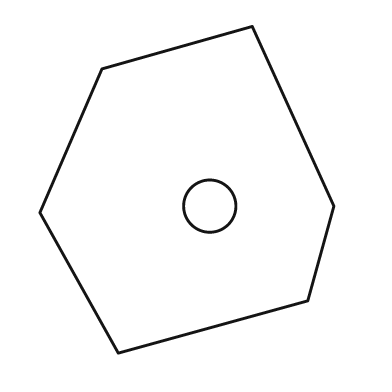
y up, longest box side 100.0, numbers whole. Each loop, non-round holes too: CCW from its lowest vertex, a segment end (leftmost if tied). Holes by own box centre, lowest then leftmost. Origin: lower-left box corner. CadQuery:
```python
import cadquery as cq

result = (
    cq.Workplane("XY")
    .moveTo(24.0, 0.0)
    .lineTo(82.0, 16.0)
    .lineTo(90.0, 45.0)
    .lineTo(65.0, 100.0)
    .lineTo(19.0, 87.0)
    .lineTo(0.0, 43.0)
    .close()
    .moveTo(52.0, 45.0)
    .circle(8.0)
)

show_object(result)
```